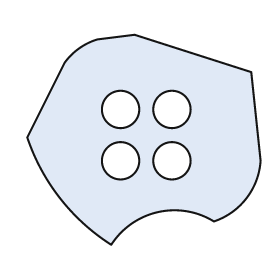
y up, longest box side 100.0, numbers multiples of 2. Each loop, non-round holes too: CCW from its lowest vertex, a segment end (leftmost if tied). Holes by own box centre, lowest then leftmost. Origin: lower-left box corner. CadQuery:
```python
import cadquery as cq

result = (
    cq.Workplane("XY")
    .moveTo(36.0, 0.0)
    .threePointArc((56.0, 14.0), (80.0, 10.0))
    .threePointArc((94.0, 20.0), (100.0, 36.0))
    .lineTo(96.0, 74.0)
    .lineTo(46.0, 90.0)
    .lineTo(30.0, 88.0)
    .threePointArc((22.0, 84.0), (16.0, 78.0))
    .lineTo(0.0, 46.0)
    .threePointArc((14.0, 20.0), (36.0, 0.0))
    .close()
    .moveTo(40.0, 36.0)
    .circle(8.0)
    .moveTo(62.0, 36.0)
    .circle(8.0)
    .moveTo(40.0, 58.0)
    .circle(8.0)
    .moveTo(62.0, 58.0)
    .circle(8.0)
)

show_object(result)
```